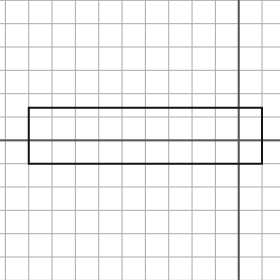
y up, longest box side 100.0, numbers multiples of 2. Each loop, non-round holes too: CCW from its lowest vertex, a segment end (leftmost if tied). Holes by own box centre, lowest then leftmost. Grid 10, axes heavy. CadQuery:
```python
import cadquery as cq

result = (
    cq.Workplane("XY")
    .moveTo(-90.0, -10.0)
    .lineTo(10.0, -10.0)
    .lineTo(10.0, 14.0)
    .lineTo(-90.0, 14.0)
    .close()
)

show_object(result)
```